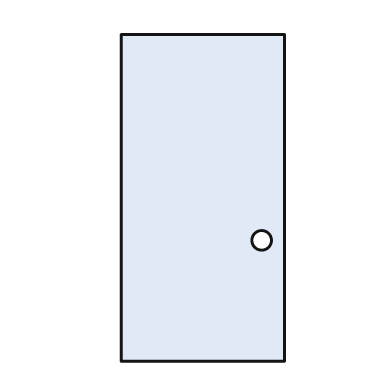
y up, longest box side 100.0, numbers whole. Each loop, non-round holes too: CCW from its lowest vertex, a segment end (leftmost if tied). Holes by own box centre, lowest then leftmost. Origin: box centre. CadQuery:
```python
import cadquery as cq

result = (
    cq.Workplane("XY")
    .moveTo(-25.0, -50.0)
    .lineTo(25.0, -50.0)
    .lineTo(25.0, 50.0)
    .lineTo(-25.0, 50.0)
    .close()
    .moveTo(18.0, -13.0)
    .circle(3.0)
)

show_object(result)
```